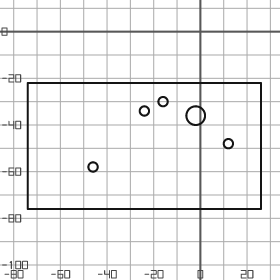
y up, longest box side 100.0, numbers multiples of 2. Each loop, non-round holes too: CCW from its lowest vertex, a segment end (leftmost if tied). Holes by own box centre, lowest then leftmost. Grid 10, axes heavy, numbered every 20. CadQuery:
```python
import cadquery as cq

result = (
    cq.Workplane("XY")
    .moveTo(-74.0, -76.0)
    .lineTo(26.0, -76.0)
    .lineTo(26.0, -22.0)
    .lineTo(-74.0, -22.0)
    .close()
    .moveTo(-46.0, -58.0)
    .circle(2.0)
    .moveTo(12.0, -48.0)
    .circle(2.0)
    .moveTo(-2.0, -36.0)
    .circle(4.0)
    .moveTo(-24.0, -34.0)
    .circle(2.0)
    .moveTo(-16.0, -30.0)
    .circle(2.0)
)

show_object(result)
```